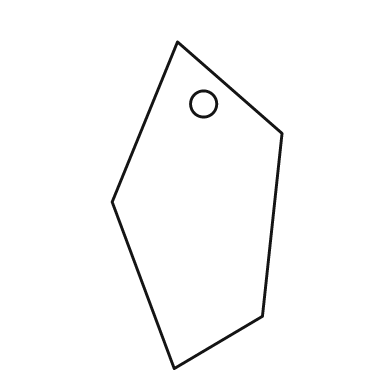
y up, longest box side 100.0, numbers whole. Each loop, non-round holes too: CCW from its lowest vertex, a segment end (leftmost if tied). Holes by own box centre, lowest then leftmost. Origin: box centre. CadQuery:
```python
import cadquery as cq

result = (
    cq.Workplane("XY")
    .moveTo(-7.0, -50.0)
    .lineTo(20.0, -34.0)
    .lineTo(26.0, 22.0)
    .lineTo(-6.0, 50.0)
    .lineTo(-26.0, 1.0)
    .close()
    .moveTo(2.0, 31.0)
    .circle(4.0)
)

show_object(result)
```